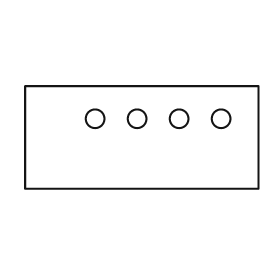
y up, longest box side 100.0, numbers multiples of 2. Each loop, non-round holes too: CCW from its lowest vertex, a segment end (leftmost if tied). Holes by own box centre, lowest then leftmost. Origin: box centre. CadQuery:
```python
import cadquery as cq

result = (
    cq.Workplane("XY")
    .moveTo(-50.0, -22.0)
    .lineTo(50.0, -22.0)
    .lineTo(50.0, 22.0)
    .lineTo(-50.0, 22.0)
    .close()
    .moveTo(-20.0, 8.0)
    .circle(4.0)
    .moveTo(-2.0, 8.0)
    .circle(4.0)
    .moveTo(16.0, 8.0)
    .circle(4.0)
    .moveTo(34.0, 8.0)
    .circle(4.0)
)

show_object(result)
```